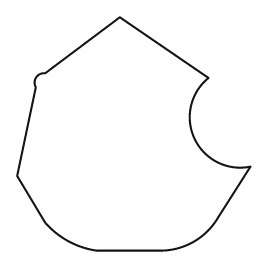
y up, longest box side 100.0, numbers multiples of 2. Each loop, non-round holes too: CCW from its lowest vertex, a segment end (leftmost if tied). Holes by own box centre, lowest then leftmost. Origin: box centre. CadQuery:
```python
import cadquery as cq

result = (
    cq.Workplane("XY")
    .moveTo(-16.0, -50.0)
    .lineTo(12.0, -50.0)
    .threePointArc((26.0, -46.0), (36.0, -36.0))
    .lineTo(50.0, -14.0)
    .threePointArc((26.0, -2.0), (32.0, 24.0))
    .lineTo(-6.0, 50.0)
    .lineTo(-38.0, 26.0)
    .threePointArc((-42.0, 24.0), (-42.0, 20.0))
    .lineTo(-50.0, -18.0)
    .lineTo(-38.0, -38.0)
    .threePointArc((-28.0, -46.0), (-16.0, -50.0))
    .close()
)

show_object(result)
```